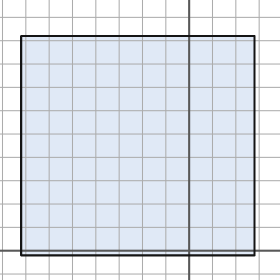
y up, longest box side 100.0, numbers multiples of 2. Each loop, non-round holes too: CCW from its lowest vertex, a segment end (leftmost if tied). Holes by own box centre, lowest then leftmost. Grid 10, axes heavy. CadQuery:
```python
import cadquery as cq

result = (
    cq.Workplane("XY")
    .moveTo(-72.0, -2.0)
    .lineTo(28.0, -2.0)
    .lineTo(28.0, 92.0)
    .lineTo(-72.0, 92.0)
    .close()
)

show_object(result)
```